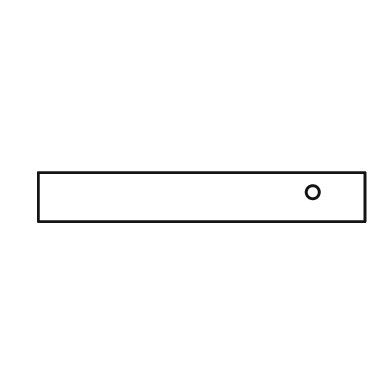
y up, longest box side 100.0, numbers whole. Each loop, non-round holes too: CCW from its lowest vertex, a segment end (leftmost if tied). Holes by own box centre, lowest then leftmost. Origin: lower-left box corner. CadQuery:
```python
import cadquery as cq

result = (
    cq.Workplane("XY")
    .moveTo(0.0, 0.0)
    .lineTo(100.0, 0.0)
    .lineTo(100.0, 15.0)
    .lineTo(0.0, 15.0)
    .close()
    .moveTo(84.0, 9.0)
    .circle(2.0)
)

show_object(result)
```